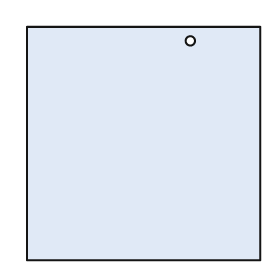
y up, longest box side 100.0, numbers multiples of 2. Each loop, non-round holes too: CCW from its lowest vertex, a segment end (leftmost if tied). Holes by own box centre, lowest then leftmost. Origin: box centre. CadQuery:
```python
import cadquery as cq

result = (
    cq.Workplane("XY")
    .moveTo(-50.0, -50.0)
    .lineTo(50.0, -50.0)
    .lineTo(50.0, 50.0)
    .lineTo(-50.0, 50.0)
    .close()
    .moveTo(20.0, 44.0)
    .circle(2.0)
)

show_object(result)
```